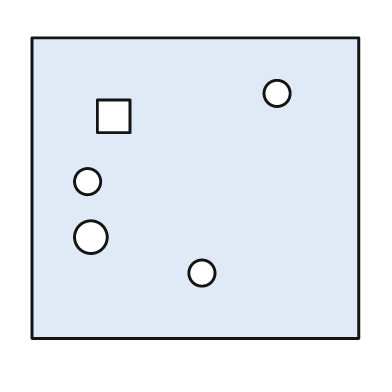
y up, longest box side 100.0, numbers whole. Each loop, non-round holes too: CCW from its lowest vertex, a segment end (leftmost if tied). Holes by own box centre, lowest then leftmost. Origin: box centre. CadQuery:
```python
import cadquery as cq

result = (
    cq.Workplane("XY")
    .moveTo(-50.0, -46.0)
    .lineTo(50.0, -46.0)
    .lineTo(50.0, 46.0)
    .lineTo(-50.0, 46.0)
    .close()
    .moveTo(2.0, -26.0)
    .circle(4.0)
    .moveTo(-32.0, -15.0)
    .circle(5.0)
    .moveTo(-33.0, 2.0)
    .circle(4.0)
    .moveTo(-30.0, 17.0)
    .lineTo(-20.0, 17.0)
    .lineTo(-20.0, 27.0)
    .lineTo(-30.0, 27.0)
    .close()
    .moveTo(25.0, 29.0)
    .circle(4.0)
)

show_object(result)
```